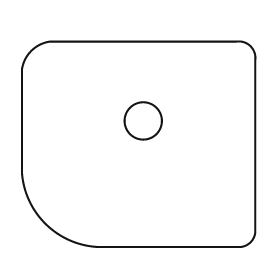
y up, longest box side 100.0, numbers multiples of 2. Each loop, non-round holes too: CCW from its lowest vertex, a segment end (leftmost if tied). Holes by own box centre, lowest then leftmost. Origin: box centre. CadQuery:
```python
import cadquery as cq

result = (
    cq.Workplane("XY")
    .moveTo(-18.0, -44.0)
    .lineTo(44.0, -44.0)
    .threePointArc((48.0, -42.0), (50.0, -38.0))
    .lineTo(50.0, 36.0)
    .threePointArc((48.0, 42.0), (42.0, 44.0))
    .lineTo(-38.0, 44.0)
    .threePointArc((-46.0, 40.0), (-50.0, 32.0))
    .lineTo(-50.0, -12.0)
    .threePointArc((-40.0, -34.0), (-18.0, -44.0))
    .close()
    .moveTo(2.0, 10.0)
    .circle(8.0)
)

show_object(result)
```